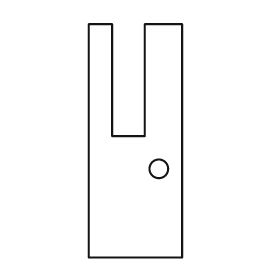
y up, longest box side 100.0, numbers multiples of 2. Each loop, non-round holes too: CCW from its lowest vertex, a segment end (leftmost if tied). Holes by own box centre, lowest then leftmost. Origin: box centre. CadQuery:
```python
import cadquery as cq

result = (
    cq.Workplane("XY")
    .moveTo(-20.0, -50.0)
    .lineTo(20.0, -50.0)
    .lineTo(20.0, 50.0)
    .lineTo(4.0, 50.0)
    .lineTo(4.0, 2.0)
    .lineTo(-10.0, 2.0)
    .lineTo(-10.0, 50.0)
    .lineTo(-20.0, 50.0)
    .close()
    .moveTo(10.0, -12.0)
    .circle(4.0)
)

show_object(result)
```